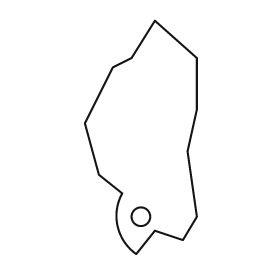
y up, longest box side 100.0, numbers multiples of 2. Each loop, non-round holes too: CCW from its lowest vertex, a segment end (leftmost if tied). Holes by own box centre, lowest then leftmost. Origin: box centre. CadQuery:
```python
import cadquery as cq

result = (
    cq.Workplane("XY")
    .moveTo(-2.0, -50.0)
    .lineTo(6.0, -40.0)
    .lineTo(18.0, -44.0)
    .lineTo(24.0, -34.0)
    .lineTo(20.0, -6.0)
    .lineTo(24.0, 12.0)
    .lineTo(24.0, 34.0)
    .lineTo(6.0, 50.0)
    .lineTo(-4.0, 34.0)
    .lineTo(-12.0, 30.0)
    .lineTo(-24.0, 6.0)
    .lineTo(-18.0, -16.0)
    .lineTo(-8.0, -24.0)
    .threePointArc((-10.0, -38.0), (-2.0, -50.0))
    .close()
    .moveTo(0.0, -34.0)
    .circle(4.0)
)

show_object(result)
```